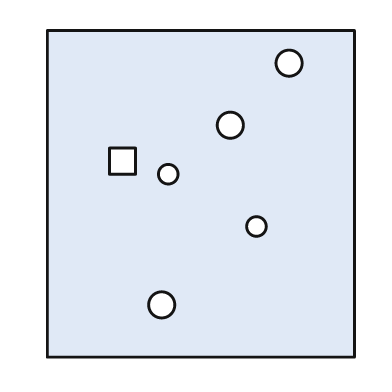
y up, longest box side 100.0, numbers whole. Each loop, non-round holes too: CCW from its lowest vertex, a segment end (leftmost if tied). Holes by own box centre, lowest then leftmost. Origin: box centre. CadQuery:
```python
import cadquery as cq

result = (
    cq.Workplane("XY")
    .moveTo(-47.0, -50.0)
    .lineTo(47.0, -50.0)
    .lineTo(47.0, 50.0)
    .lineTo(-47.0, 50.0)
    .close()
    .moveTo(-12.0, -34.0)
    .circle(4.0)
    .moveTo(17.0, -10.0)
    .circle(3.0)
    .moveTo(-10.0, 6.0)
    .circle(3.0)
    .moveTo(-28.0, 6.0)
    .lineTo(-20.0, 6.0)
    .lineTo(-20.0, 14.0)
    .lineTo(-28.0, 14.0)
    .close()
    .moveTo(9.0, 21.0)
    .circle(4.0)
    .moveTo(27.0, 40.0)
    .circle(4.0)
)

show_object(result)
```